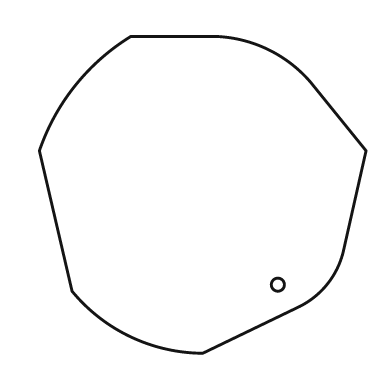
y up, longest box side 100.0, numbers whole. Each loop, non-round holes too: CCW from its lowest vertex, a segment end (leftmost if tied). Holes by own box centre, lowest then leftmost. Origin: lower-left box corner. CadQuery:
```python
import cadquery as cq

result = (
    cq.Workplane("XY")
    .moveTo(50.0, 0.0)
    .lineTo(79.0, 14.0)
    .threePointArc((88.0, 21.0), (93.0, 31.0))
    .lineTo(100.0, 62.0)
    .lineTo(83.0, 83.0)
    .threePointArc((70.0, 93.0), (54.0, 97.0))
    .lineTo(28.0, 97.0)
    .threePointArc((11.0, 82.0), (0.0, 62.0))
    .lineTo(10.0, 19.0)
    .threePointArc((28.0, 5.0), (50.0, 0.0))
    .close()
    .moveTo(73.0, 21.0)
    .circle(2.0)
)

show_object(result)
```